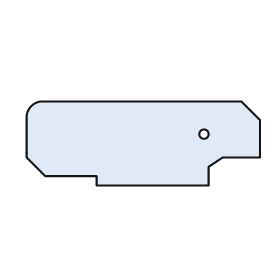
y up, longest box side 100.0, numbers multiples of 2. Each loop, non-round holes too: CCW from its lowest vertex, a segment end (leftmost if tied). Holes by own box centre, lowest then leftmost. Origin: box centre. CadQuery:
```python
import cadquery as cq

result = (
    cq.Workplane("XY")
    .moveTo(-20.0, -18.0)
    .lineTo(28.0, -18.0)
    .lineTo(28.0, -10.0)
    .lineTo(34.0, -6.0)
    .lineTo(50.0, -6.0)
    .lineTo(50.0, 10.0)
    .lineTo(42.0, 18.0)
    .lineTo(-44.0, 18.0)
    .threePointArc((-48.0, 16.0), (-50.0, 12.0))
    .lineTo(-50.0, -6.0)
    .lineTo(-42.0, -14.0)
    .lineTo(-20.0, -14.0)
    .close()
    .moveTo(26.0, 4.0)
    .circle(2.0)
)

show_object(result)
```